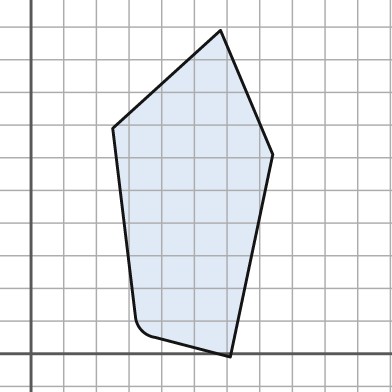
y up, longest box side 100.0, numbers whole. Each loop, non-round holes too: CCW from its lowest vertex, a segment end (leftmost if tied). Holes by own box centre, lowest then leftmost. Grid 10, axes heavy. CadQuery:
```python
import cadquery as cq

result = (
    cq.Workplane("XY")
    .moveTo(61.0, -1.0)
    .lineTo(74.0, 61.0)
    .lineTo(58.0, 99.0)
    .lineTo(25.0, 69.0)
    .lineTo(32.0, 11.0)
    .threePointArc((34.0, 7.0), (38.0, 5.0))
    .close()
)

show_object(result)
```